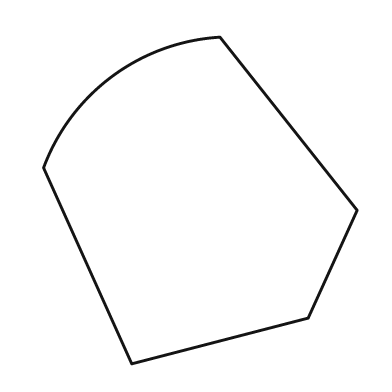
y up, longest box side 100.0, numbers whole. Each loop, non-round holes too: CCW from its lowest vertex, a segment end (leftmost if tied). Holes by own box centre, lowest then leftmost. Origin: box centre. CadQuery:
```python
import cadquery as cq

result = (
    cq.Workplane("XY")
    .moveTo(-21.0, -50.0)
    .lineTo(33.0, -36.0)
    .lineTo(48.0, -3.0)
    .lineTo(6.0, 50.0)
    .threePointArc((-27.0, 38.0), (-48.0, 10.0))
    .close()
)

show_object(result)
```